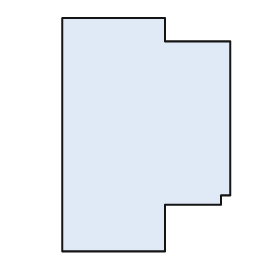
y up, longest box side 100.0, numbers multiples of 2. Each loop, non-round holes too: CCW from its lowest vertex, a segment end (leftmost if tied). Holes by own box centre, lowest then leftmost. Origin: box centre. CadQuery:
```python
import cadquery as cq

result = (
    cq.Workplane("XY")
    .moveTo(-36.0, -50.0)
    .lineTo(8.0, -50.0)
    .lineTo(8.0, -30.0)
    .lineTo(32.0, -30.0)
    .lineTo(32.0, -26.0)
    .lineTo(36.0, -26.0)
    .lineTo(36.0, 40.0)
    .lineTo(8.0, 40.0)
    .lineTo(8.0, 50.0)
    .lineTo(-36.0, 50.0)
    .close()
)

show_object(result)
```